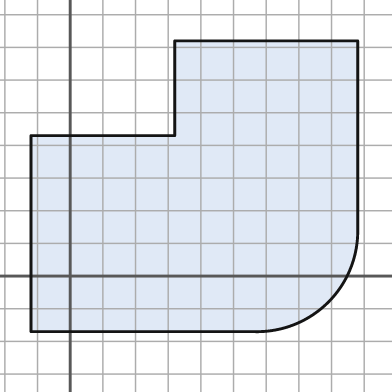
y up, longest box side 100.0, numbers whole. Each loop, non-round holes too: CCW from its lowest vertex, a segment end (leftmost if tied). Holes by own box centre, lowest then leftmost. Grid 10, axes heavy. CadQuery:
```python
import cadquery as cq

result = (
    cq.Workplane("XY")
    .moveTo(-12.0, -17.0)
    .lineTo(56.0, -17.0)
    .threePointArc((79.0, -8.0), (88.0, 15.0))
    .lineTo(88.0, 72.0)
    .lineTo(32.0, 72.0)
    .lineTo(32.0, 43.0)
    .lineTo(-12.0, 43.0)
    .close()
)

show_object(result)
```